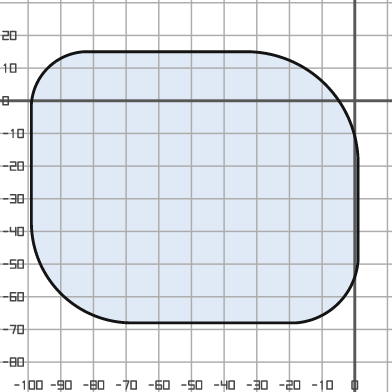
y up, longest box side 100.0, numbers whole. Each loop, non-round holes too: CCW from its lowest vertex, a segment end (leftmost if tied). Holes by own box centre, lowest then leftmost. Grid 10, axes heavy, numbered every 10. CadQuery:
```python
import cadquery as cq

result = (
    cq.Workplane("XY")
    .moveTo(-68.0, -68.0)
    .lineTo(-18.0, -68.0)
    .threePointArc((-5.0, -62.0), (1.0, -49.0))
    .lineTo(1.0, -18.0)
    .threePointArc((-9.0, 5.0), (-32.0, 15.0))
    .lineTo(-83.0, 15.0)
    .threePointArc((-94.0, 10.0), (-99.0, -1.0))
    .lineTo(-99.0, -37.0)
    .threePointArc((-90.0, -59.0), (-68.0, -68.0))
    .close()
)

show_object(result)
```